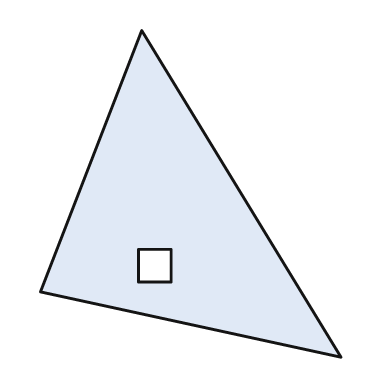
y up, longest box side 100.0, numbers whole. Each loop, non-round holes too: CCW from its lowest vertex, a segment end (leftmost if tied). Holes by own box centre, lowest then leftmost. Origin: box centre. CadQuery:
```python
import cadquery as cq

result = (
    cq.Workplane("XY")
    .moveTo(46.0, -50.0)
    .lineTo(-15.0, 50.0)
    .lineTo(-46.0, -30.0)
    .close()
    .moveTo(-16.0, -27.0)
    .lineTo(-6.0, -27.0)
    .lineTo(-6.0, -17.0)
    .lineTo(-16.0, -17.0)
    .close()
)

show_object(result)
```